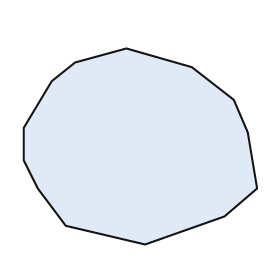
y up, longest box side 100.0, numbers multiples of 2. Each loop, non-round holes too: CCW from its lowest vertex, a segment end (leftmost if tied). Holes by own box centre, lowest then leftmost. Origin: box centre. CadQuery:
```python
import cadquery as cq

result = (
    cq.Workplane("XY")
    .moveTo(2.0, -42.0)
    .lineTo(36.0, -30.0)
    .lineTo(50.0, -18.0)
    .lineTo(46.0, 6.0)
    .lineTo(40.0, 20.0)
    .lineTo(22.0, 34.0)
    .lineTo(-6.0, 42.0)
    .lineTo(-28.0, 36.0)
    .lineTo(-38.0, 28.0)
    .lineTo(-50.0, 8.0)
    .lineTo(-50.0, -6.0)
    .lineTo(-44.0, -18.0)
    .lineTo(-32.0, -34.0)
    .close()
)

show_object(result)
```